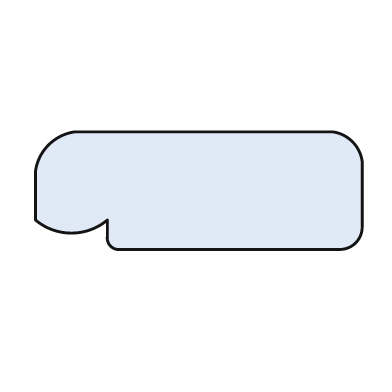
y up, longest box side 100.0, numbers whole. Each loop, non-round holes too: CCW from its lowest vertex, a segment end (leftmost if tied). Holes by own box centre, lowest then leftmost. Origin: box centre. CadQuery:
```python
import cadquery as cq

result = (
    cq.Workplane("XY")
    .moveTo(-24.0, -18.0)
    .lineTo(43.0, -18.0)
    .threePointArc((48.0, -16.0), (50.0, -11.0))
    .lineTo(50.0, 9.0)
    .threePointArc((47.0, 15.0), (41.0, 18.0))
    .lineTo(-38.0, 18.0)
    .threePointArc((-46.0, 14.0), (-50.0, 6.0))
    .lineTo(-50.0, -9.0)
    .threePointArc((-39.0, -13.0), (-28.0, -9.0))
    .lineTo(-28.0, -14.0)
    .threePointArc((-27.0, -17.0), (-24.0, -18.0))
    .close()
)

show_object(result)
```